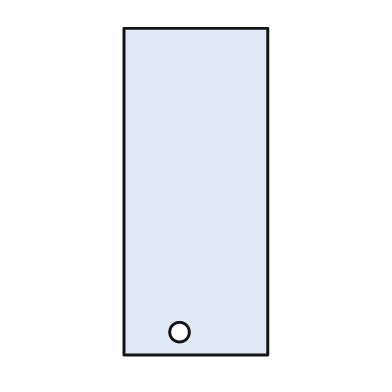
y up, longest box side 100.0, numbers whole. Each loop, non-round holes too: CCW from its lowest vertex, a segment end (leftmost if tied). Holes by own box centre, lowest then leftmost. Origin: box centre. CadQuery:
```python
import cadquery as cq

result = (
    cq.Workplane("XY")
    .moveTo(-22.0, -50.0)
    .lineTo(22.0, -50.0)
    .lineTo(22.0, 50.0)
    .lineTo(-22.0, 50.0)
    .close()
    .moveTo(-5.0, -43.0)
    .circle(3.0)
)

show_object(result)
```